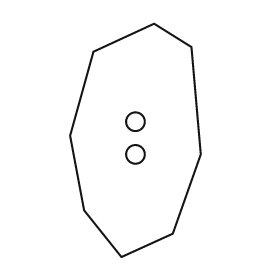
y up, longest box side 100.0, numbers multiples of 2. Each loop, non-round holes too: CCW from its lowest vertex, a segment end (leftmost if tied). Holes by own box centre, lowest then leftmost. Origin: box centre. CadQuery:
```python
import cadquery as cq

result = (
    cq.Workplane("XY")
    .moveTo(-6.0, -50.0)
    .lineTo(16.0, -40.0)
    .lineTo(28.0, -6.0)
    .lineTo(24.0, 40.0)
    .lineTo(8.0, 50.0)
    .lineTo(-18.0, 38.0)
    .lineTo(-28.0, 2.0)
    .lineTo(-22.0, -30.0)
    .close()
    .moveTo(0.0, -6.0)
    .circle(4.0)
    .moveTo(0.0, 8.0)
    .circle(4.0)
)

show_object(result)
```